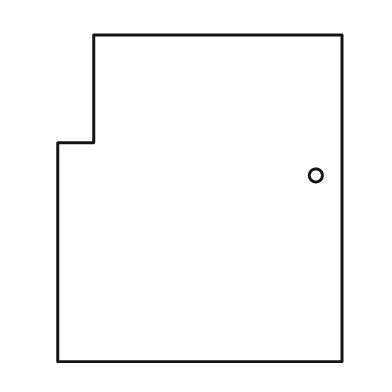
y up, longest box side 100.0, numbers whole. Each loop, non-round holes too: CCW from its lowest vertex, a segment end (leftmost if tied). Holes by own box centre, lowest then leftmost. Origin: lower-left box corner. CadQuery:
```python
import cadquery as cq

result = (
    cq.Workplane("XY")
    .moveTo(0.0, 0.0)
    .lineTo(87.0, 0.0)
    .lineTo(87.0, 100.0)
    .lineTo(11.0, 100.0)
    .lineTo(11.0, 67.0)
    .lineTo(0.0, 67.0)
    .close()
    .moveTo(79.0, 57.0)
    .circle(2.0)
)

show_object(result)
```